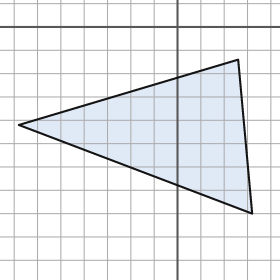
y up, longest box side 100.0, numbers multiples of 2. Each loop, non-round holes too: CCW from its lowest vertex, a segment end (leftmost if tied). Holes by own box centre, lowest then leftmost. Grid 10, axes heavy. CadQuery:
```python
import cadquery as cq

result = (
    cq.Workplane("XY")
    .moveTo(32.0, -80.0)
    .lineTo(26.0, -14.0)
    .lineTo(-68.0, -42.0)
    .close()
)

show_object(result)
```